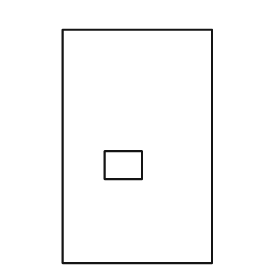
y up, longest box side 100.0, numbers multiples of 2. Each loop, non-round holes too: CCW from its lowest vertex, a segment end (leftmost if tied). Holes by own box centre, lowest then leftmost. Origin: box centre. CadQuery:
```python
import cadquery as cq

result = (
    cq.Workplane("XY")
    .moveTo(-32.0, -50.0)
    .lineTo(32.0, -50.0)
    .lineTo(32.0, 50.0)
    .lineTo(-32.0, 50.0)
    .close()
    .moveTo(-14.0, -14.0)
    .lineTo(2.0, -14.0)
    .lineTo(2.0, -2.0)
    .lineTo(-14.0, -2.0)
    .close()
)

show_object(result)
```